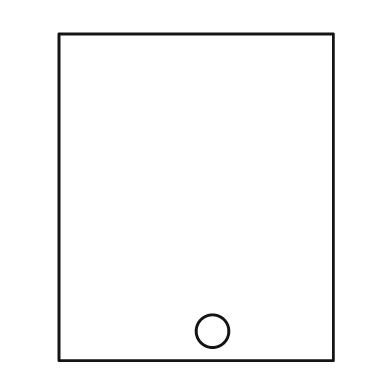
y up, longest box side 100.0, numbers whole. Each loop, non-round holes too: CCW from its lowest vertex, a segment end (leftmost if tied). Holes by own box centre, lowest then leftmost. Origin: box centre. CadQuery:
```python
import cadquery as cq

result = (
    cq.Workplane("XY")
    .moveTo(-42.0, -50.0)
    .lineTo(42.0, -50.0)
    .lineTo(42.0, 50.0)
    .lineTo(-42.0, 50.0)
    .close()
    .moveTo(5.0, -41.0)
    .circle(5.0)
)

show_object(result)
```